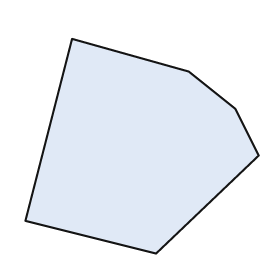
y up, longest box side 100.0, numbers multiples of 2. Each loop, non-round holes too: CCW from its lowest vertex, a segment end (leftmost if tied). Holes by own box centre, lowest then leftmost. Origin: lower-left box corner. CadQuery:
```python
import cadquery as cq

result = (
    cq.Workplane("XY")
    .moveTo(56.0, 0.0)
    .lineTo(100.0, 42.0)
    .lineTo(90.0, 62.0)
    .lineTo(70.0, 78.0)
    .lineTo(20.0, 92.0)
    .lineTo(0.0, 14.0)
    .close()
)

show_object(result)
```